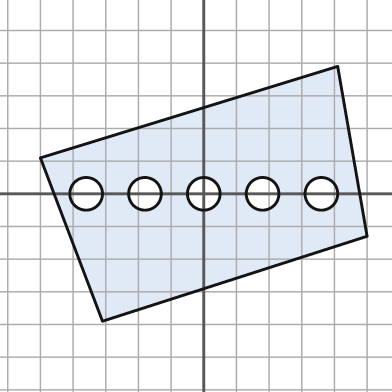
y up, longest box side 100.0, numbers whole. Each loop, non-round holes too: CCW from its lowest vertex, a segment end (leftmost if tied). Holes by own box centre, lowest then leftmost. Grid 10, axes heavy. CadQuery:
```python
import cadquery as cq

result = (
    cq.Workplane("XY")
    .moveTo(-31.0, -39.0)
    .lineTo(50.0, -13.0)
    .lineTo(41.0, 39.0)
    .lineTo(-50.0, 11.0)
    .close()
    .moveTo(-36.0, 0.0)
    .circle(5.0)
    .moveTo(-18.0, 0.0)
    .circle(5.0)
    .moveTo(0.0, 0.0)
    .circle(5.0)
    .moveTo(18.0, 0.0)
    .circle(5.0)
    .moveTo(36.0, 0.0)
    .circle(5.0)
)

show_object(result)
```